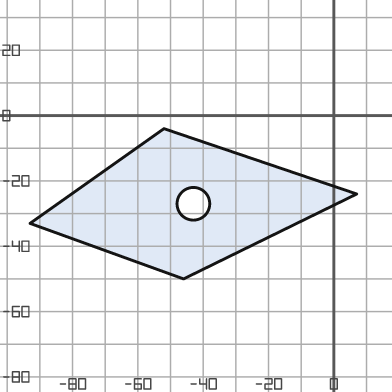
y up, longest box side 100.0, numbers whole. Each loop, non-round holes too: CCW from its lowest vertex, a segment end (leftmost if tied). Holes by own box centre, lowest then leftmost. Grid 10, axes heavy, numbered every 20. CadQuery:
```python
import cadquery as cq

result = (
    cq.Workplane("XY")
    .moveTo(-46.0, -50.0)
    .lineTo(7.0, -24.0)
    .lineTo(-52.0, -4.0)
    .lineTo(-93.0, -33.0)
    .close()
    .moveTo(-43.0, -27.0)
    .circle(5.0)
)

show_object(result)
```